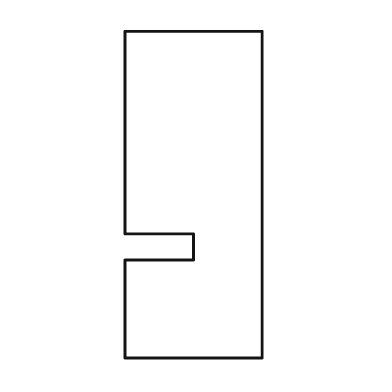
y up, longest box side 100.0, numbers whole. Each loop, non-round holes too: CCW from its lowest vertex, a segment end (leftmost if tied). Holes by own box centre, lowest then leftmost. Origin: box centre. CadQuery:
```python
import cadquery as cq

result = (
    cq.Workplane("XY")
    .moveTo(-21.0, -50.0)
    .lineTo(21.0, -50.0)
    .lineTo(21.0, 50.0)
    .lineTo(-21.0, 50.0)
    .lineTo(-21.0, -12.0)
    .lineTo(0.0, -12.0)
    .lineTo(0.0, -20.0)
    .lineTo(-21.0, -20.0)
    .close()
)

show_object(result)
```